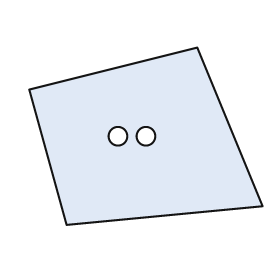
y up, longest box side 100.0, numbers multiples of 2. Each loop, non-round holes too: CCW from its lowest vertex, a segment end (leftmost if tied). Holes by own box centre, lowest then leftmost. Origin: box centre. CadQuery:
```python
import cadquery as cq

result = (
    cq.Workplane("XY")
    .moveTo(-34.0, -38.0)
    .lineTo(50.0, -30.0)
    .lineTo(22.0, 38.0)
    .lineTo(-50.0, 20.0)
    .close()
    .moveTo(-12.0, 0.0)
    .circle(4.0)
    .moveTo(0.0, 0.0)
    .circle(4.0)
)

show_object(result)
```